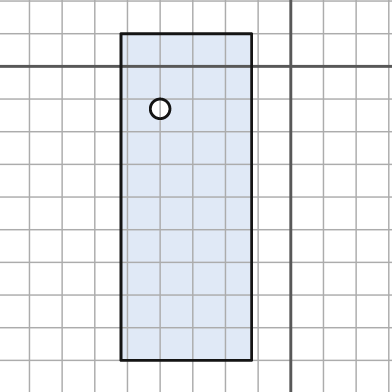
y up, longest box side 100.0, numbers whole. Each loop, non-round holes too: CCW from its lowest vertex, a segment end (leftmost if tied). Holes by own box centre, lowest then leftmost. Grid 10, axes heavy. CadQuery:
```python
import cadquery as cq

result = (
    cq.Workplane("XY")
    .moveTo(-52.0, -90.0)
    .lineTo(-12.0, -90.0)
    .lineTo(-12.0, 10.0)
    .lineTo(-52.0, 10.0)
    .close()
    .moveTo(-40.0, -13.0)
    .circle(3.0)
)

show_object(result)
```